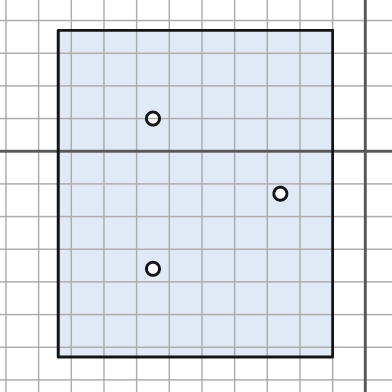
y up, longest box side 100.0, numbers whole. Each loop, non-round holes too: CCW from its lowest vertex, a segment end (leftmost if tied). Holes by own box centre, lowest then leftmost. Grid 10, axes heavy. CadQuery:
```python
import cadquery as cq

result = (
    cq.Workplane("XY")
    .moveTo(-94.0, -63.0)
    .lineTo(-10.0, -63.0)
    .lineTo(-10.0, 37.0)
    .lineTo(-94.0, 37.0)
    .close()
    .moveTo(-65.0, -36.0)
    .circle(2.0)
    .moveTo(-26.0, -13.0)
    .circle(2.0)
    .moveTo(-65.0, 10.0)
    .circle(2.0)
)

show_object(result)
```